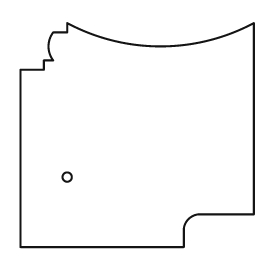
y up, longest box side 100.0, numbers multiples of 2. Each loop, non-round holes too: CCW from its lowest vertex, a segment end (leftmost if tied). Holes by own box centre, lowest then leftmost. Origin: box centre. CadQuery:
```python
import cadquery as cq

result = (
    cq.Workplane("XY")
    .moveTo(-50.0, -48.0)
    .lineTo(20.0, -48.0)
    .lineTo(20.0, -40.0)
    .threePointArc((22.0, -36.0), (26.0, -34.0))
    .lineTo(50.0, -34.0)
    .lineTo(50.0, 48.0)
    .threePointArc((10.0, 38.0), (-30.0, 48.0))
    .lineTo(-30.0, 44.0)
    .lineTo(-36.0, 44.0)
    .threePointArc((-38.0, 38.0), (-36.0, 32.0))
    .lineTo(-40.0, 32.0)
    .lineTo(-40.0, 28.0)
    .lineTo(-50.0, 28.0)
    .close()
    .moveTo(-30.0, -18.0)
    .circle(2.0)
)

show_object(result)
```